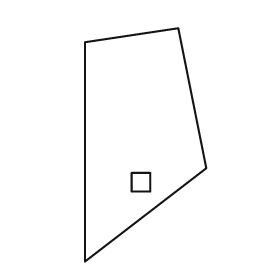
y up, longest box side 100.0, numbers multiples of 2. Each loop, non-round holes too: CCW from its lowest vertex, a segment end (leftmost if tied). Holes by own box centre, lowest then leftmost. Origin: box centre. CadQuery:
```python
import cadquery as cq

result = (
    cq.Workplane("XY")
    .moveTo(-26.0, -50.0)
    .lineTo(26.0, -10.0)
    .lineTo(14.0, 50.0)
    .lineTo(-26.0, 44.0)
    .close()
    .moveTo(-6.0, -20.0)
    .lineTo(2.0, -20.0)
    .lineTo(2.0, -12.0)
    .lineTo(-6.0, -12.0)
    .close()
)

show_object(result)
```